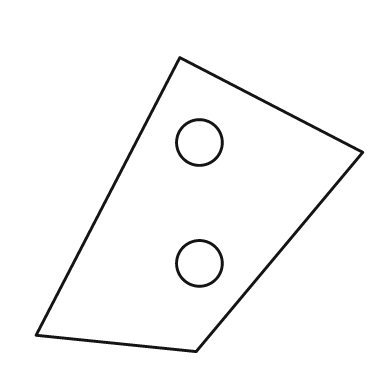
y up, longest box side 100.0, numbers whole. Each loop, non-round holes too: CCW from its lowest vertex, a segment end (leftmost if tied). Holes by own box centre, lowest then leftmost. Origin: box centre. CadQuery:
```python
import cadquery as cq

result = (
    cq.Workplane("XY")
    .moveTo(-1.0, -45.0)
    .lineTo(50.0, 16.0)
    .lineTo(-6.0, 45.0)
    .lineTo(-50.0, -40.0)
    .close()
    .moveTo(0.0, -18.0)
    .circle(7.0)
    .moveTo(0.0, 19.0)
    .circle(7.0)
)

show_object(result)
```